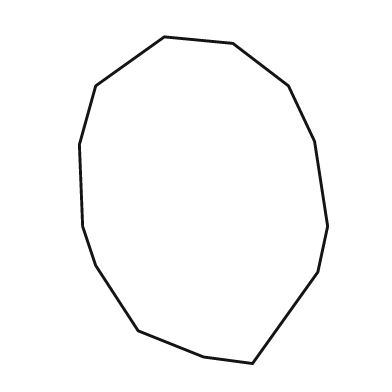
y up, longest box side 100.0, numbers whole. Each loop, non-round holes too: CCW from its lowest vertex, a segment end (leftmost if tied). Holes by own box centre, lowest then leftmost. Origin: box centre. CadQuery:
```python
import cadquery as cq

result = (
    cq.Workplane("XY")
    .moveTo(15.0, -50.0)
    .lineTo(35.0, -22.0)
    .lineTo(38.0, -8.0)
    .lineTo(34.0, 18.0)
    .lineTo(26.0, 35.0)
    .lineTo(9.0, 48.0)
    .lineTo(-12.0, 50.0)
    .lineTo(-33.0, 35.0)
    .lineTo(-38.0, 17.0)
    .lineTo(-37.0, -8.0)
    .lineTo(-33.0, -20.0)
    .lineTo(-20.0, -40.0)
    .lineTo(0.0, -48.0)
    .close()
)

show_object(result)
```